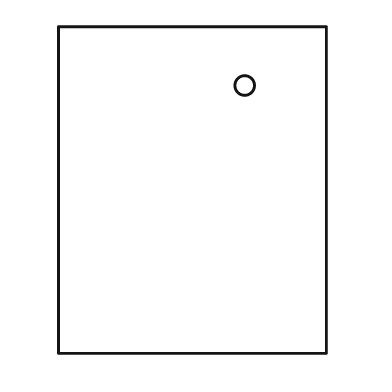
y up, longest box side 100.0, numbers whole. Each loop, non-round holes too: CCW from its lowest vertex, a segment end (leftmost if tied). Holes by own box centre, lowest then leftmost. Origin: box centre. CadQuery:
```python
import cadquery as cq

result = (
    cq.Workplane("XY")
    .moveTo(-41.0, -50.0)
    .lineTo(41.0, -50.0)
    .lineTo(41.0, 50.0)
    .lineTo(-41.0, 50.0)
    .close()
    .moveTo(16.0, 32.0)
    .circle(3.0)
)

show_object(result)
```